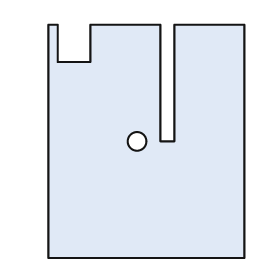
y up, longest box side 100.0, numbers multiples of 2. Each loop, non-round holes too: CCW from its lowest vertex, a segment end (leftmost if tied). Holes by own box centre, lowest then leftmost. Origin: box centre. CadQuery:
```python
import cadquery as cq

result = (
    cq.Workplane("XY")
    .moveTo(-42.0, -50.0)
    .lineTo(42.0, -50.0)
    .lineTo(42.0, 50.0)
    .lineTo(12.0, 50.0)
    .lineTo(12.0, 0.0)
    .lineTo(6.0, 0.0)
    .lineTo(6.0, 50.0)
    .lineTo(-24.0, 50.0)
    .lineTo(-24.0, 34.0)
    .lineTo(-38.0, 34.0)
    .lineTo(-38.0, 50.0)
    .lineTo(-42.0, 50.0)
    .close()
    .moveTo(-4.0, 0.0)
    .circle(4.0)
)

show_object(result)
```